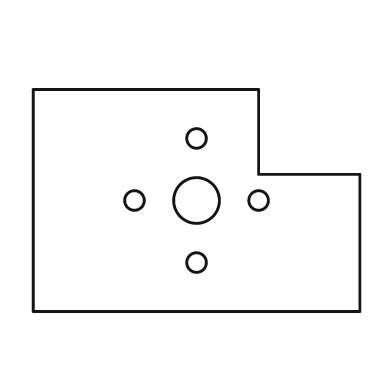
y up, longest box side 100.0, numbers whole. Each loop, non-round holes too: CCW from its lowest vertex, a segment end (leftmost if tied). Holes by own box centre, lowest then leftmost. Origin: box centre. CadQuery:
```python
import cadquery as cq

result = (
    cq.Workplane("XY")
    .moveTo(-50.0, -34.0)
    .lineTo(50.0, -34.0)
    .lineTo(50.0, 8.0)
    .lineTo(19.0, 8.0)
    .lineTo(19.0, 34.0)
    .lineTo(-50.0, 34.0)
    .close()
    .moveTo(0.0, -19.0)
    .circle(3.0)
    .moveTo(-19.0, 0.0)
    .circle(3.0)
    .moveTo(0.0, 0.0)
    .circle(7.0)
    .moveTo(19.0, 0.0)
    .circle(3.0)
    .moveTo(0.0, 19.0)
    .circle(3.0)
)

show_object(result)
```